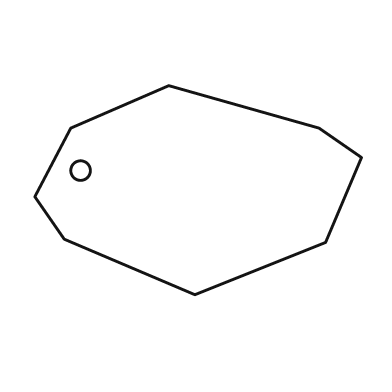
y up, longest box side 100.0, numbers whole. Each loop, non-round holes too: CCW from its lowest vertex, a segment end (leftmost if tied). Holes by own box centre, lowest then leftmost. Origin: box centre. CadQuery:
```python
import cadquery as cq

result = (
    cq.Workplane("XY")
    .moveTo(-1.0, -32.0)
    .lineTo(39.0, -16.0)
    .lineTo(50.0, 10.0)
    .lineTo(37.0, 19.0)
    .lineTo(-9.0, 32.0)
    .lineTo(-39.0, 19.0)
    .lineTo(-50.0, -2.0)
    .lineTo(-41.0, -15.0)
    .close()
    .moveTo(-36.0, 6.0)
    .circle(3.0)
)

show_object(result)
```